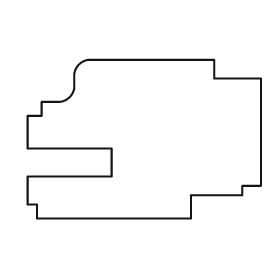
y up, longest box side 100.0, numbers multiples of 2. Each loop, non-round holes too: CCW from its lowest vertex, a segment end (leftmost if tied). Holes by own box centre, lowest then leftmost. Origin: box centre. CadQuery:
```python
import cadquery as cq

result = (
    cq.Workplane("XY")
    .moveTo(-46.0, -34.0)
    .lineTo(20.0, -34.0)
    .lineTo(20.0, -24.0)
    .lineTo(42.0, -24.0)
    .lineTo(42.0, -20.0)
    .lineTo(50.0, -20.0)
    .lineTo(50.0, 26.0)
    .lineTo(30.0, 26.0)
    .lineTo(30.0, 34.0)
    .lineTo(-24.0, 34.0)
    .threePointArc((-28.0, 32.0), (-30.0, 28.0))
    .lineTo(-30.0, 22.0)
    .threePointArc((-32.0, 18.0), (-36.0, 16.0))
    .lineTo(-44.0, 16.0)
    .lineTo(-44.0, 10.0)
    .lineTo(-50.0, 10.0)
    .lineTo(-50.0, -4.0)
    .lineTo(-14.0, -4.0)
    .lineTo(-14.0, -16.0)
    .lineTo(-50.0, -16.0)
    .lineTo(-50.0, -28.0)
    .lineTo(-46.0, -28.0)
    .close()
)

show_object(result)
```